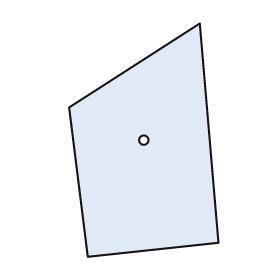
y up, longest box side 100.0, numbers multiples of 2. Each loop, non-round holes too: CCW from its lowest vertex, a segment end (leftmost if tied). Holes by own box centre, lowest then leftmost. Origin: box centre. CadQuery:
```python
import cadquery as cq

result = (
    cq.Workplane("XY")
    .moveTo(-24.0, -50.0)
    .lineTo(32.0, -44.0)
    .lineTo(24.0, 50.0)
    .lineTo(-32.0, 14.0)
    .close()
    .moveTo(0.0, 0.0)
    .circle(2.0)
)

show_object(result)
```